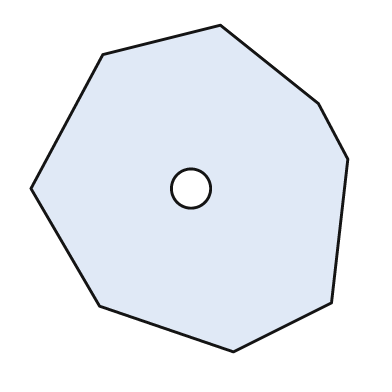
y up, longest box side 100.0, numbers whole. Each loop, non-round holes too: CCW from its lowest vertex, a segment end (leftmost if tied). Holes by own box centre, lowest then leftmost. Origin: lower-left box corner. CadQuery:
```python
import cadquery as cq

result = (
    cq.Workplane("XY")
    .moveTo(62.0, 0.0)
    .lineTo(92.0, 15.0)
    .lineTo(97.0, 59.0)
    .lineTo(88.0, 76.0)
    .lineTo(58.0, 100.0)
    .lineTo(22.0, 91.0)
    .lineTo(0.0, 50.0)
    .lineTo(21.0, 14.0)
    .close()
    .moveTo(49.0, 50.0)
    .circle(6.0)
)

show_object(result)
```